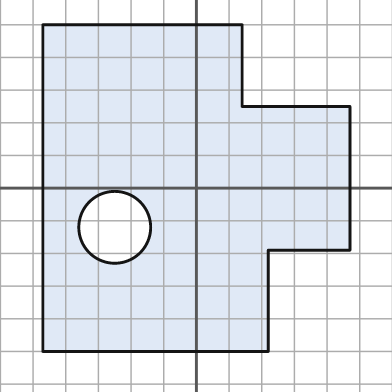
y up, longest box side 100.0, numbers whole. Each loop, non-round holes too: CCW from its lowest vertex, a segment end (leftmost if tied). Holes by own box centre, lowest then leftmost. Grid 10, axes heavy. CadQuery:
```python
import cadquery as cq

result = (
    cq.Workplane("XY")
    .moveTo(-47.0, -50.0)
    .lineTo(22.0, -50.0)
    .lineTo(22.0, -19.0)
    .lineTo(47.0, -19.0)
    .lineTo(47.0, 25.0)
    .lineTo(14.0, 25.0)
    .lineTo(14.0, 50.0)
    .lineTo(-47.0, 50.0)
    .close()
    .moveTo(-25.0, -12.0)
    .circle(11.0)
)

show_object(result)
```